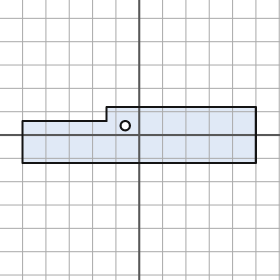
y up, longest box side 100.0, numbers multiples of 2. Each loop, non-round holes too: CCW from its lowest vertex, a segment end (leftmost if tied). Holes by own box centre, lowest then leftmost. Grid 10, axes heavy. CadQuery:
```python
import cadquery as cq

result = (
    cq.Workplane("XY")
    .moveTo(-50.0, -12.0)
    .lineTo(50.0, -12.0)
    .lineTo(50.0, 12.0)
    .lineTo(-14.0, 12.0)
    .lineTo(-14.0, 6.0)
    .lineTo(-50.0, 6.0)
    .close()
    .moveTo(-6.0, 4.0)
    .circle(2.0)
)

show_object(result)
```